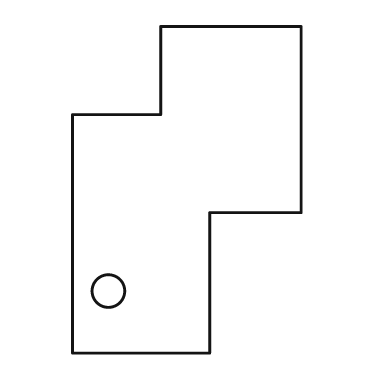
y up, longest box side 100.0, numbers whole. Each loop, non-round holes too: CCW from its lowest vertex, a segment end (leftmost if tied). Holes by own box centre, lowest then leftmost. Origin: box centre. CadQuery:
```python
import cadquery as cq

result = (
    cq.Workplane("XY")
    .moveTo(-35.0, -50.0)
    .lineTo(7.0, -50.0)
    .lineTo(7.0, -7.0)
    .lineTo(35.0, -7.0)
    .lineTo(35.0, 50.0)
    .lineTo(-8.0, 50.0)
    .lineTo(-8.0, 23.0)
    .lineTo(-35.0, 23.0)
    .close()
    .moveTo(-24.0, -31.0)
    .circle(5.0)
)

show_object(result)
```